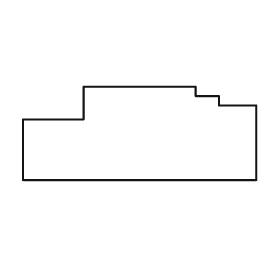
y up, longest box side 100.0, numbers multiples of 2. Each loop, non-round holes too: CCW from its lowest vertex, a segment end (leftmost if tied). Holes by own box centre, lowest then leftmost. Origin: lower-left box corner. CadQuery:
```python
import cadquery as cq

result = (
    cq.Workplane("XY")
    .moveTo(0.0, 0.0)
    .lineTo(100.0, 0.0)
    .lineTo(100.0, 32.0)
    .lineTo(84.0, 32.0)
    .lineTo(84.0, 36.0)
    .lineTo(74.0, 36.0)
    .lineTo(74.0, 40.0)
    .lineTo(26.0, 40.0)
    .lineTo(26.0, 26.0)
    .lineTo(0.0, 26.0)
    .close()
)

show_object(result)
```